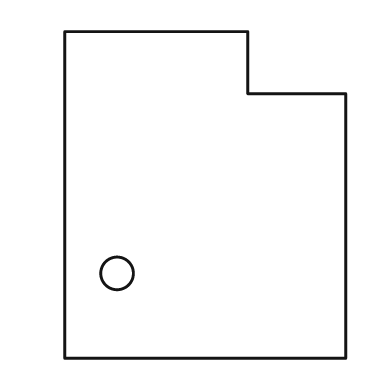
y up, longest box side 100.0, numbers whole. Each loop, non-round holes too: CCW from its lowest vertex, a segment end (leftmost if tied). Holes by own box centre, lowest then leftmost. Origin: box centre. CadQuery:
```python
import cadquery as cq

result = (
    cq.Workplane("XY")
    .moveTo(-43.0, -50.0)
    .lineTo(43.0, -50.0)
    .lineTo(43.0, 31.0)
    .lineTo(13.0, 31.0)
    .lineTo(13.0, 50.0)
    .lineTo(-43.0, 50.0)
    .close()
    .moveTo(-27.0, -24.0)
    .circle(5.0)
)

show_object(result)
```